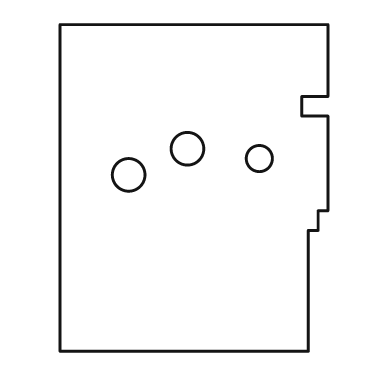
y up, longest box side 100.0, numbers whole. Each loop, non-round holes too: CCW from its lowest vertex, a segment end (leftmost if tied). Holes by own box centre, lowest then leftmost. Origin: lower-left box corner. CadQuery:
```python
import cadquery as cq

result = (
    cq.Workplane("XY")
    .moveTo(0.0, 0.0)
    .lineTo(76.0, 0.0)
    .lineTo(76.0, 37.0)
    .lineTo(79.0, 37.0)
    .lineTo(79.0, 43.0)
    .lineTo(82.0, 43.0)
    .lineTo(82.0, 72.0)
    .lineTo(74.0, 72.0)
    .lineTo(74.0, 78.0)
    .lineTo(82.0, 78.0)
    .lineTo(82.0, 100.0)
    .lineTo(0.0, 100.0)
    .close()
    .moveTo(21.0, 54.0)
    .circle(5.0)
    .moveTo(61.0, 59.0)
    .circle(4.0)
    .moveTo(39.0, 62.0)
    .circle(5.0)
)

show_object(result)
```